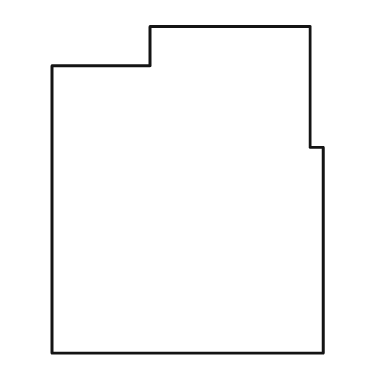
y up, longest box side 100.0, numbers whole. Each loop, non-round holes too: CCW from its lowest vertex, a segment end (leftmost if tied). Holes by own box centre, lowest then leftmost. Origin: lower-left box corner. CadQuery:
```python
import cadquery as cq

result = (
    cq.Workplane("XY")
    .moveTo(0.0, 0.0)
    .lineTo(83.0, 0.0)
    .lineTo(83.0, 63.0)
    .lineTo(79.0, 63.0)
    .lineTo(79.0, 100.0)
    .lineTo(30.0, 100.0)
    .lineTo(30.0, 88.0)
    .lineTo(0.0, 88.0)
    .close()
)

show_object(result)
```